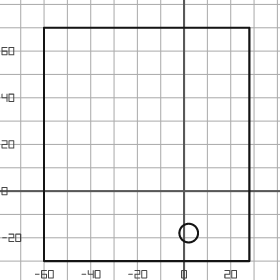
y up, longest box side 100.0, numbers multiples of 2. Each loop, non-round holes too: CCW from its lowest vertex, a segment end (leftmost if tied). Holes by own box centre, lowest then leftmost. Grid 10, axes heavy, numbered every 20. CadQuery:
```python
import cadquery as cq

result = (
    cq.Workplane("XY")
    .moveTo(-60.0, -30.0)
    .lineTo(28.0, -30.0)
    .lineTo(28.0, 70.0)
    .lineTo(-60.0, 70.0)
    .close()
    .moveTo(2.0, -18.0)
    .circle(4.0)
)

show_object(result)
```